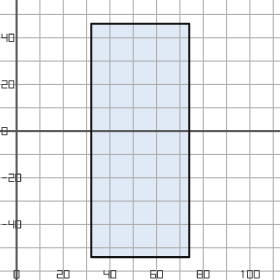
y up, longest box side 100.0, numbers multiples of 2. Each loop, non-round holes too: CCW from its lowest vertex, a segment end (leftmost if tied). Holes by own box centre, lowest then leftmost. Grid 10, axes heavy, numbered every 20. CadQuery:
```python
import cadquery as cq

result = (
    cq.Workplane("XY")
    .moveTo(32.0, -54.0)
    .lineTo(74.0, -54.0)
    .lineTo(74.0, 46.0)
    .lineTo(32.0, 46.0)
    .close()
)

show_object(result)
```